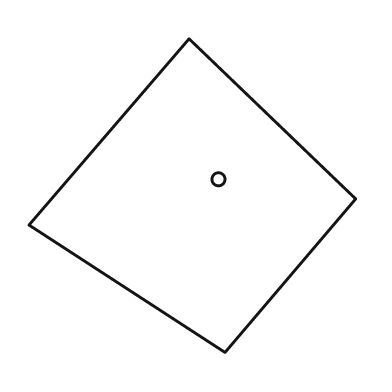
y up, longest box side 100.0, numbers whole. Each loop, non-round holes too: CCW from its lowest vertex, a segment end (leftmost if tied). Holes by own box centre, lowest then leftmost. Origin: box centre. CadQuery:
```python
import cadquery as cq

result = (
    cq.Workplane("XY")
    .moveTo(10.0, -48.0)
    .lineTo(50.0, -1.0)
    .lineTo(-1.0, 48.0)
    .lineTo(-50.0, -9.0)
    .close()
    .moveTo(8.0, 5.0)
    .circle(2.0)
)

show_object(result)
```